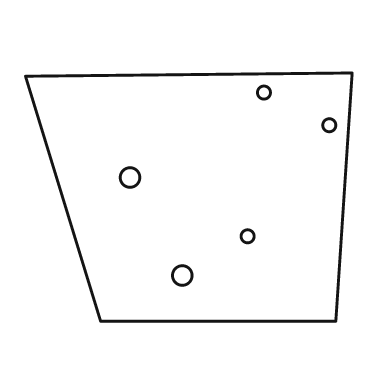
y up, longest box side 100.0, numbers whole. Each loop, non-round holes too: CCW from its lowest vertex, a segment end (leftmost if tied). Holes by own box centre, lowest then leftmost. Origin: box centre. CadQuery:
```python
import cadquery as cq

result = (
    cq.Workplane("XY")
    .moveTo(-27.0, -38.0)
    .lineTo(45.0, -38.0)
    .lineTo(50.0, 38.0)
    .lineTo(-50.0, 37.0)
    .close()
    .moveTo(-2.0, -24.0)
    .circle(3.0)
    .moveTo(18.0, -12.0)
    .circle(2.0)
    .moveTo(-18.0, 6.0)
    .circle(3.0)
    .moveTo(43.0, 22.0)
    .circle(2.0)
    .moveTo(23.0, 32.0)
    .circle(2.0)
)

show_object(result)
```